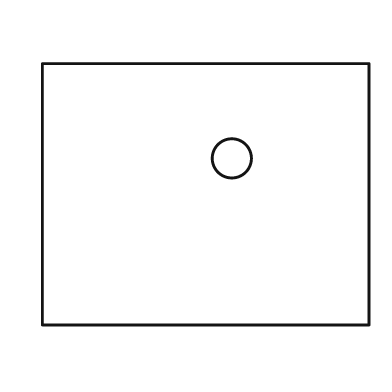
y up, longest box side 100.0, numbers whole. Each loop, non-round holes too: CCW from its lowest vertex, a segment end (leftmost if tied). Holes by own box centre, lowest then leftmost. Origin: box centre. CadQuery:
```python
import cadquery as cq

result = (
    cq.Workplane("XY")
    .moveTo(-50.0, -40.0)
    .lineTo(50.0, -40.0)
    .lineTo(50.0, 40.0)
    .lineTo(-50.0, 40.0)
    .close()
    .moveTo(8.0, 11.0)
    .circle(6.0)
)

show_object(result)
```